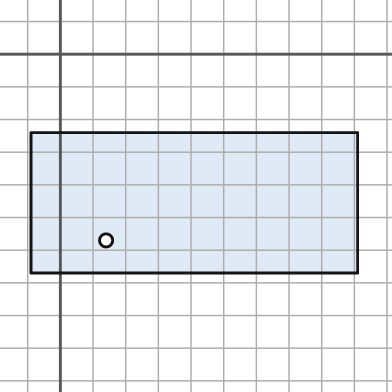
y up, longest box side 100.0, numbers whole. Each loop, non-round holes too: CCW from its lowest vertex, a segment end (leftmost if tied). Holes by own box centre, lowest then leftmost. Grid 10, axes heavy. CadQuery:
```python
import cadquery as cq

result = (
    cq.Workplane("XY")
    .moveTo(-9.0, -67.0)
    .lineTo(91.0, -67.0)
    .lineTo(91.0, -24.0)
    .lineTo(-9.0, -24.0)
    .close()
    .moveTo(14.0, -57.0)
    .circle(2.0)
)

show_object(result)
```